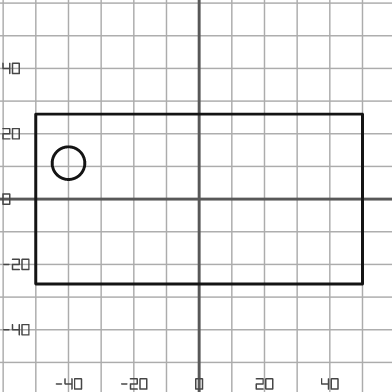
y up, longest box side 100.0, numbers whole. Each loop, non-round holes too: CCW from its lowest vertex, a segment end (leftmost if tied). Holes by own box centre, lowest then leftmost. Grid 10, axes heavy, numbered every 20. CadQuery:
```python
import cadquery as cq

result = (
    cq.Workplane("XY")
    .moveTo(-50.0, -26.0)
    .lineTo(50.0, -26.0)
    .lineTo(50.0, 26.0)
    .lineTo(-50.0, 26.0)
    .close()
    .moveTo(-40.0, 11.0)
    .circle(5.0)
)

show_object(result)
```